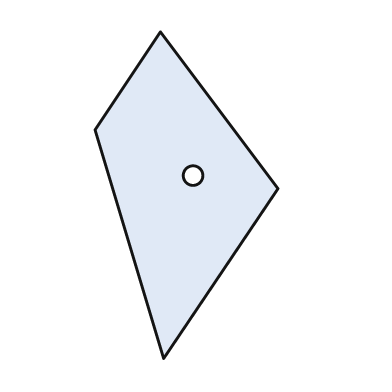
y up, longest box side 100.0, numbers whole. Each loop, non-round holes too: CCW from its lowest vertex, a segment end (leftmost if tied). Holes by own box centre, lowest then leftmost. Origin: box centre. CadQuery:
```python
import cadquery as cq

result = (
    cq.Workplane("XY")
    .moveTo(-7.0, -50.0)
    .lineTo(28.0, 2.0)
    .lineTo(-8.0, 50.0)
    .lineTo(-28.0, 20.0)
    .close()
    .moveTo(2.0, 6.0)
    .circle(3.0)
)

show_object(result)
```